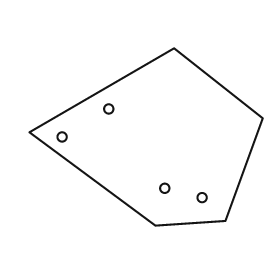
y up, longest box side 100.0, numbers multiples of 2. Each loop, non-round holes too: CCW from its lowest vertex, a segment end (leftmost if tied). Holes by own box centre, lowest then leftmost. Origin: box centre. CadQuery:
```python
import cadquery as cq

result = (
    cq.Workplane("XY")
    .moveTo(4.0, -38.0)
    .lineTo(34.0, -36.0)
    .lineTo(50.0, 8.0)
    .lineTo(12.0, 38.0)
    .lineTo(-50.0, 2.0)
    .close()
    .moveTo(24.0, -26.0)
    .circle(2.0)
    .moveTo(8.0, -22.0)
    .circle(2.0)
    .moveTo(-36.0, 0.0)
    .circle(2.0)
    .moveTo(-16.0, 12.0)
    .circle(2.0)
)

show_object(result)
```